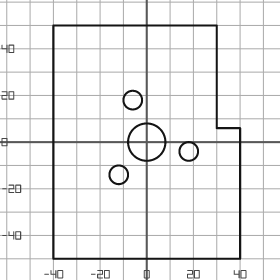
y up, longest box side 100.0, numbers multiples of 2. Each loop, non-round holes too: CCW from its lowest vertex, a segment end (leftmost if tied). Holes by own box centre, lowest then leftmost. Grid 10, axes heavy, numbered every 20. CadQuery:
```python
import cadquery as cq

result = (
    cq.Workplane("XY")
    .moveTo(-40.0, -50.0)
    .lineTo(40.0, -50.0)
    .lineTo(40.0, 6.0)
    .lineTo(30.0, 6.0)
    .lineTo(30.0, 50.0)
    .lineTo(-40.0, 50.0)
    .close()
    .moveTo(-12.0, -14.0)
    .circle(4.0)
    .moveTo(18.0, -4.0)
    .circle(4.0)
    .moveTo(0.0, 0.0)
    .circle(8.0)
    .moveTo(-6.0, 18.0)
    .circle(4.0)
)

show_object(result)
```